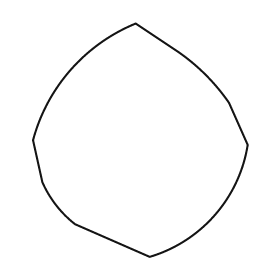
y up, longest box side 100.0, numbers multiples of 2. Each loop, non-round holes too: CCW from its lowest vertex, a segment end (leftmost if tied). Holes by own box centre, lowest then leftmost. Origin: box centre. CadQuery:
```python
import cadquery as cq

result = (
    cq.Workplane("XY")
    .moveTo(4.0, -50.0)
    .threePointArc((32.0, -32.0), (46.0, -2.0))
    .lineTo(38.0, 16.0)
    .threePointArc((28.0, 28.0), (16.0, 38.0))
    .lineTo(-2.0, 50.0)
    .threePointArc((-30.0, 30.0), (-46.0, 0.0))
    .lineTo(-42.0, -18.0)
    .threePointArc((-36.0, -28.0), (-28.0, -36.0))
    .close()
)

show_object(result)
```